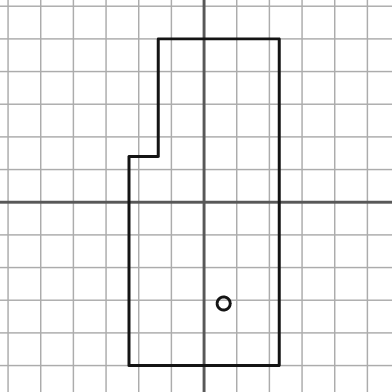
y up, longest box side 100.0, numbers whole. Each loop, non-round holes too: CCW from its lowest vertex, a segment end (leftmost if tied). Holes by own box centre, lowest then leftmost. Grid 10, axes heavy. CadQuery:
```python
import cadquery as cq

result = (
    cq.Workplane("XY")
    .moveTo(-23.0, -50.0)
    .lineTo(23.0, -50.0)
    .lineTo(23.0, 50.0)
    .lineTo(-14.0, 50.0)
    .lineTo(-14.0, 14.0)
    .lineTo(-23.0, 14.0)
    .close()
    .moveTo(6.0, -31.0)
    .circle(2.0)
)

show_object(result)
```